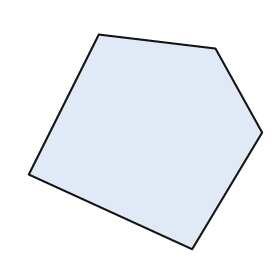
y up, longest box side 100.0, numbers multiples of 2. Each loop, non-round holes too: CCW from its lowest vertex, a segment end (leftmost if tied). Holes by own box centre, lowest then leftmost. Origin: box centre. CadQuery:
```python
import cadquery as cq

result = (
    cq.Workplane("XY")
    .moveTo(20.0, -46.0)
    .lineTo(50.0, 4.0)
    .lineTo(30.0, 40.0)
    .lineTo(-20.0, 46.0)
    .lineTo(-50.0, -14.0)
    .close()
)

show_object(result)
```